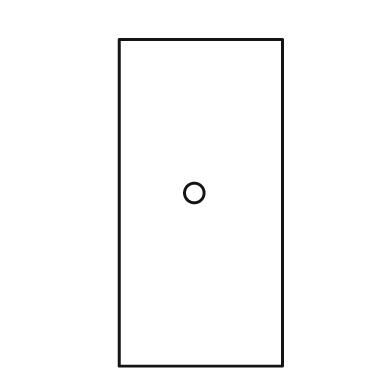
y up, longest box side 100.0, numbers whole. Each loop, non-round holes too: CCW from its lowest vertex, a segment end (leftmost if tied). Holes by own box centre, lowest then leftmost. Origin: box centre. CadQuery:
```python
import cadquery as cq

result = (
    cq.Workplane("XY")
    .moveTo(-25.0, -50.0)
    .lineTo(25.0, -50.0)
    .lineTo(25.0, 50.0)
    .lineTo(-25.0, 50.0)
    .close()
    .moveTo(-2.0, 3.0)
    .circle(3.0)
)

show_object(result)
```